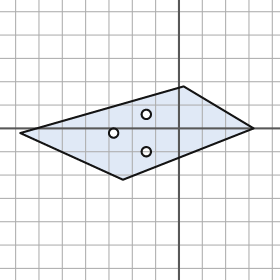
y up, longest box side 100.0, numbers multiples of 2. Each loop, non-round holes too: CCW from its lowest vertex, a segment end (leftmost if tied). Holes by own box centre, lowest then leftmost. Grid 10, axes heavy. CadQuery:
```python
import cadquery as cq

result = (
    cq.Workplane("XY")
    .moveTo(-24.0, -22.0)
    .lineTo(32.0, 0.0)
    .lineTo(2.0, 18.0)
    .lineTo(-68.0, -2.0)
    .close()
    .moveTo(-14.0, -10.0)
    .circle(2.0)
    .moveTo(-28.0, -2.0)
    .circle(2.0)
    .moveTo(-14.0, 6.0)
    .circle(2.0)
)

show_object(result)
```